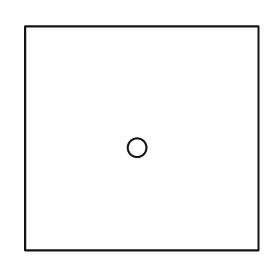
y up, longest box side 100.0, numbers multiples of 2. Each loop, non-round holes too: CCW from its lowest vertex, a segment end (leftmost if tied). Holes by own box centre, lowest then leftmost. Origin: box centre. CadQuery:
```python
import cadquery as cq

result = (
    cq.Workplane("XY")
    .moveTo(-50.0, -48.0)
    .lineTo(50.0, -48.0)
    .lineTo(50.0, 48.0)
    .lineTo(-50.0, 48.0)
    .close()
    .moveTo(-2.0, -4.0)
    .circle(4.0)
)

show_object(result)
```